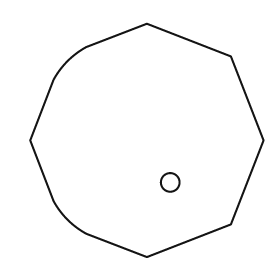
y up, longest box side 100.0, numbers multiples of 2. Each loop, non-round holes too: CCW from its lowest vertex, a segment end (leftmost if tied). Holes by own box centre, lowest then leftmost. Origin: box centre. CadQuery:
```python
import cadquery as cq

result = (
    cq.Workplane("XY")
    .moveTo(0.0, -50.0)
    .lineTo(36.0, -36.0)
    .lineTo(50.0, 0.0)
    .lineTo(36.0, 36.0)
    .lineTo(0.0, 50.0)
    .lineTo(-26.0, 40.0)
    .threePointArc((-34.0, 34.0), (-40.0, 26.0))
    .lineTo(-50.0, 0.0)
    .lineTo(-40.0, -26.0)
    .threePointArc((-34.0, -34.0), (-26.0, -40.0))
    .close()
    .moveTo(10.0, -18.0)
    .circle(4.0)
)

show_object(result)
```